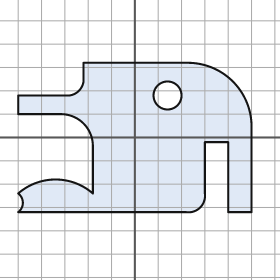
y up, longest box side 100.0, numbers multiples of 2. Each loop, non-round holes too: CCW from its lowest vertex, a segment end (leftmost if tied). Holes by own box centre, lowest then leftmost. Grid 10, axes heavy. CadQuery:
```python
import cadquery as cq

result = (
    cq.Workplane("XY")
    .moveTo(-50.0, -32.0)
    .lineTo(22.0, -32.0)
    .threePointArc((28.0, -30.0), (30.0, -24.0))
    .lineTo(30.0, -2.0)
    .lineTo(40.0, -2.0)
    .lineTo(40.0, -32.0)
    .lineTo(50.0, -32.0)
    .lineTo(50.0, 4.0)
    .threePointArc((42.0, 24.0), (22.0, 32.0))
    .lineTo(-22.0, 32.0)
    .lineTo(-22.0, 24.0)
    .threePointArc((-24.0, 20.0), (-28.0, 18.0))
    .lineTo(-50.0, 18.0)
    .lineTo(-50.0, 10.0)
    .lineTo(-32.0, 10.0)
    .threePointArc((-22.0, 6.0), (-18.0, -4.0))
    .lineTo(-18.0, -24.0)
    .threePointArc((-34.0, -18.0), (-50.0, -24.0))
    .threePointArc((-48.0, -28.0), (-50.0, -32.0))
    .close()
    .moveTo(14.0, 18.0)
    .circle(6.0)
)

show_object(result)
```